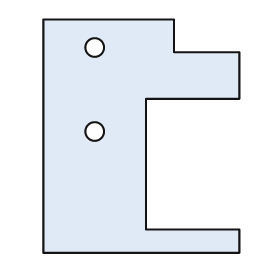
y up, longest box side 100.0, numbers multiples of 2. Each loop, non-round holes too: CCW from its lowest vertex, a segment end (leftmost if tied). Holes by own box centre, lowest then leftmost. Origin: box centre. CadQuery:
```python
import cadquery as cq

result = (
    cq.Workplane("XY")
    .moveTo(-42.0, -50.0)
    .lineTo(42.0, -50.0)
    .lineTo(42.0, -40.0)
    .lineTo(2.0, -40.0)
    .lineTo(2.0, 16.0)
    .lineTo(42.0, 16.0)
    .lineTo(42.0, 36.0)
    .lineTo(14.0, 36.0)
    .lineTo(14.0, 50.0)
    .lineTo(-42.0, 50.0)
    .close()
    .moveTo(-20.0, 2.0)
    .circle(4.0)
    .moveTo(-20.0, 38.0)
    .circle(4.0)
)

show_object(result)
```